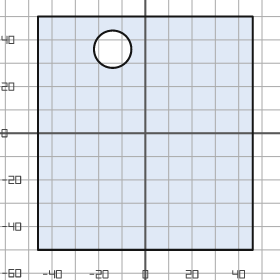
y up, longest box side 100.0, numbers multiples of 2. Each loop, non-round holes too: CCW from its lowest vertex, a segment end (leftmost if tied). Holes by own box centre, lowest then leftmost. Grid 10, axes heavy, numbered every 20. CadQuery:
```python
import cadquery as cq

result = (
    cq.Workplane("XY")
    .moveTo(-46.0, -50.0)
    .lineTo(46.0, -50.0)
    .lineTo(46.0, 50.0)
    .lineTo(-46.0, 50.0)
    .close()
    .moveTo(-14.0, 36.0)
    .circle(8.0)
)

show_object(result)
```